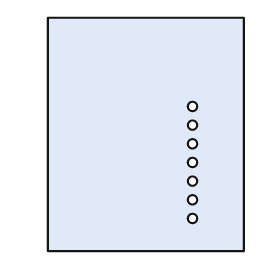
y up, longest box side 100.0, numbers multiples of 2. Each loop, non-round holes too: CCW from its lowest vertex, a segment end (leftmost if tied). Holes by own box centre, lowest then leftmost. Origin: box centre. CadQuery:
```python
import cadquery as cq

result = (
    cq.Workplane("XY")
    .moveTo(-42.0, -50.0)
    .lineTo(42.0, -50.0)
    .lineTo(42.0, 50.0)
    .lineTo(-42.0, 50.0)
    .close()
    .moveTo(20.0, -36.0)
    .circle(2.0)
    .moveTo(20.0, -28.0)
    .circle(2.0)
    .moveTo(20.0, -20.0)
    .circle(2.0)
    .moveTo(20.0, -12.0)
    .circle(2.0)
    .moveTo(20.0, -4.0)
    .circle(2.0)
    .moveTo(20.0, 4.0)
    .circle(2.0)
    .moveTo(20.0, 12.0)
    .circle(2.0)
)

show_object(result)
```